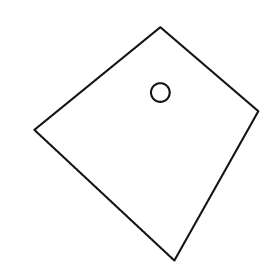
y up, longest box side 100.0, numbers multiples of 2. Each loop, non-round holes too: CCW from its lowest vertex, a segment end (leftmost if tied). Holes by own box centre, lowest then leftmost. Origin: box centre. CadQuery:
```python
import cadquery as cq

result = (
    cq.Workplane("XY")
    .moveTo(12.0, -50.0)
    .lineTo(48.0, 14.0)
    .lineTo(6.0, 50.0)
    .lineTo(-48.0, 6.0)
    .close()
    .moveTo(6.0, 22.0)
    .circle(4.0)
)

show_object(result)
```